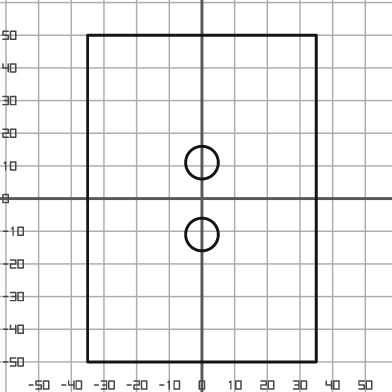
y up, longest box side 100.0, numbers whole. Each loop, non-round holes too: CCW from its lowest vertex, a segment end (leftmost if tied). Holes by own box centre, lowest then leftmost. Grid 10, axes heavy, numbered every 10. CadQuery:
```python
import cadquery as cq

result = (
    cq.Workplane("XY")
    .moveTo(-35.0, -50.0)
    .lineTo(35.0, -50.0)
    .lineTo(35.0, 50.0)
    .lineTo(-35.0, 50.0)
    .close()
    .moveTo(0.0, -11.0)
    .circle(5.0)
    .moveTo(0.0, 11.0)
    .circle(5.0)
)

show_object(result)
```